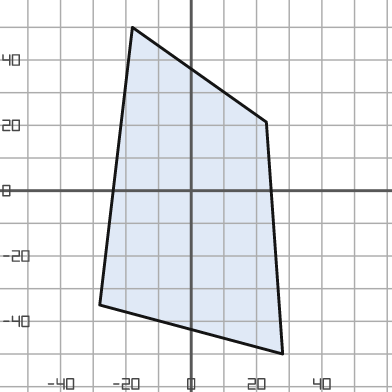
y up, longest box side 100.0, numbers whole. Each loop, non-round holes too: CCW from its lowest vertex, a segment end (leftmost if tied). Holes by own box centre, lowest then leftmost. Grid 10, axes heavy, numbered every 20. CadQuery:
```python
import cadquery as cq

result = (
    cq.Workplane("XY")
    .moveTo(28.0, -50.0)
    .lineTo(23.0, 21.0)
    .lineTo(-18.0, 50.0)
    .lineTo(-28.0, -35.0)
    .close()
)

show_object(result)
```